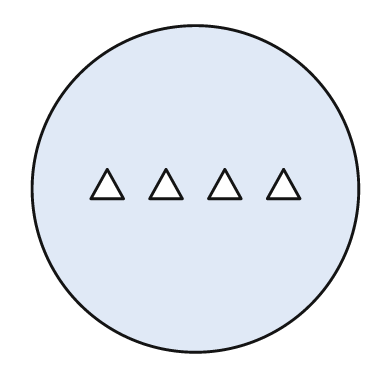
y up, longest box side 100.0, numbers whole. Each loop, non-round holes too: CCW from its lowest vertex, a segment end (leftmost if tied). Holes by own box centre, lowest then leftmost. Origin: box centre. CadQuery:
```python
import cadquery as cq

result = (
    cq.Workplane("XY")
    .moveTo(0.0, 0.0)
    .circle(50.0)
    .moveTo(-32.0, -3.0)
    .lineTo(-22.0, -3.0)
    .lineTo(-27.0, 6.0)
    .close()
    .moveTo(-14.0, -3.0)
    .lineTo(-4.0, -3.0)
    .lineTo(-9.0, 6.0)
    .close()
    .moveTo(4.0, -3.0)
    .lineTo(14.0, -3.0)
    .lineTo(9.0, 6.0)
    .close()
    .moveTo(22.0, -3.0)
    .lineTo(32.0, -3.0)
    .lineTo(27.0, 6.0)
    .close()
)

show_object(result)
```